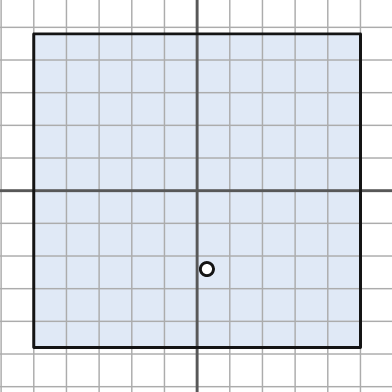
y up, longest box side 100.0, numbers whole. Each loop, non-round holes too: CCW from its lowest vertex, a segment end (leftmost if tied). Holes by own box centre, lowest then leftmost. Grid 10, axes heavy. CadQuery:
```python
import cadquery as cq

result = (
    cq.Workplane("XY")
    .moveTo(-50.0, -48.0)
    .lineTo(50.0, -48.0)
    .lineTo(50.0, 48.0)
    .lineTo(-50.0, 48.0)
    .close()
    .moveTo(3.0, -24.0)
    .circle(2.0)
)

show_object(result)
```